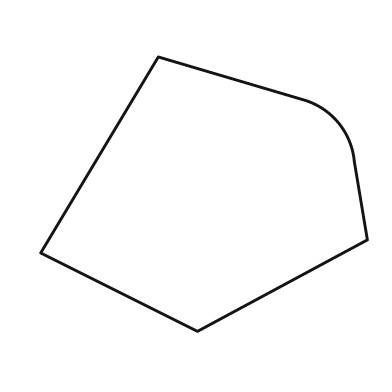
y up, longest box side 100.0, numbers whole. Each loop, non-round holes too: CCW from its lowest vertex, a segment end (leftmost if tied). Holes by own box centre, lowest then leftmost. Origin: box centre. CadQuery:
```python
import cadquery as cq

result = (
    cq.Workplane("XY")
    .moveTo(-2.0, -42.0)
    .lineTo(50.0, -14.0)
    .lineTo(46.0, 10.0)
    .threePointArc((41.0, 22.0), (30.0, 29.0))
    .lineTo(-14.0, 42.0)
    .lineTo(-50.0, -18.0)
    .close()
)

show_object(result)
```